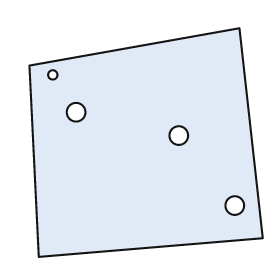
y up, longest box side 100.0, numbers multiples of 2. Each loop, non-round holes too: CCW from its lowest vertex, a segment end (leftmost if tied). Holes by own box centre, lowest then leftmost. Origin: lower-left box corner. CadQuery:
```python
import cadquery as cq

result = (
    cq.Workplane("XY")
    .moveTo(4.0, 0.0)
    .lineTo(100.0, 8.0)
    .lineTo(90.0, 98.0)
    .lineTo(0.0, 82.0)
    .close()
    .moveTo(88.0, 22.0)
    .circle(4.0)
    .moveTo(64.0, 52.0)
    .circle(4.0)
    .moveTo(20.0, 62.0)
    .circle(4.0)
    .moveTo(10.0, 78.0)
    .circle(2.0)
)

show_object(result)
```